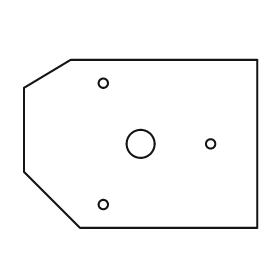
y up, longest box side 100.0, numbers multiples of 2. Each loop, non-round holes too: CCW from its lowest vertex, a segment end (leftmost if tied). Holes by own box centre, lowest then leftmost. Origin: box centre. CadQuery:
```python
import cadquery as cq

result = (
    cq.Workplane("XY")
    .moveTo(-26.0, -36.0)
    .lineTo(50.0, -36.0)
    .lineTo(50.0, 36.0)
    .lineTo(-30.0, 36.0)
    .lineTo(-50.0, 24.0)
    .lineTo(-50.0, -12.0)
    .close()
    .moveTo(-16.0, -26.0)
    .circle(2.0)
    .moveTo(0.0, 0.0)
    .circle(6.0)
    .moveTo(30.0, 0.0)
    .circle(2.0)
    .moveTo(-16.0, 26.0)
    .circle(2.0)
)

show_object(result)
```